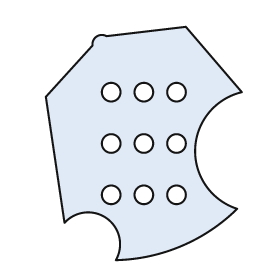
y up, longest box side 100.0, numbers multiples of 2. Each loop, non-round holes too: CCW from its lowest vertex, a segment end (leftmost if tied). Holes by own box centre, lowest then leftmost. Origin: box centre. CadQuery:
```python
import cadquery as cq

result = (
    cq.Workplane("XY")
    .moveTo(-12.0, -50.0)
    .threePointArc((16.0, -44.0), (40.0, -28.0))
    .threePointArc((22.0, -2.0), (42.0, 22.0))
    .lineTo(18.0, 50.0)
    .lineTo(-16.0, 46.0)
    .threePointArc((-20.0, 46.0), (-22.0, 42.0))
    .lineTo(-42.0, 20.0)
    .lineTo(-34.0, -34.0)
    .threePointArc((-16.0, -32.0), (-12.0, -50.0))
    .close()
    .moveTo(-14.0, -22.0)
    .circle(4.0)
    .moveTo(0.0, -22.0)
    .circle(4.0)
    .moveTo(14.0, -22.0)
    .circle(4.0)
    .moveTo(-14.0, 0.0)
    .circle(4.0)
    .moveTo(0.0, 0.0)
    .circle(4.0)
    .moveTo(14.0, 0.0)
    .circle(4.0)
    .moveTo(-14.0, 22.0)
    .circle(4.0)
    .moveTo(0.0, 22.0)
    .circle(4.0)
    .moveTo(14.0, 22.0)
    .circle(4.0)
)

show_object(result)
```